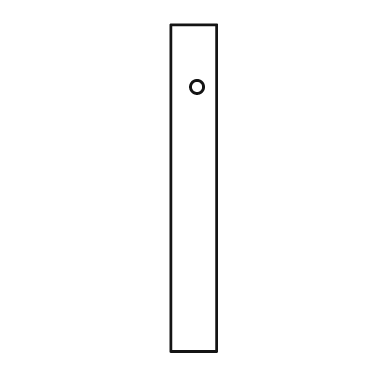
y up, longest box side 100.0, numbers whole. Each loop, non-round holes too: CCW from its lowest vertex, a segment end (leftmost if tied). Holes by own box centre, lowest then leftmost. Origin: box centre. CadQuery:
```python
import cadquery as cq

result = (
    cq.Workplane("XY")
    .moveTo(-7.0, -50.0)
    .lineTo(7.0, -50.0)
    .lineTo(7.0, 50.0)
    .lineTo(-7.0, 50.0)
    .close()
    .moveTo(1.0, 31.0)
    .circle(2.0)
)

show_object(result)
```